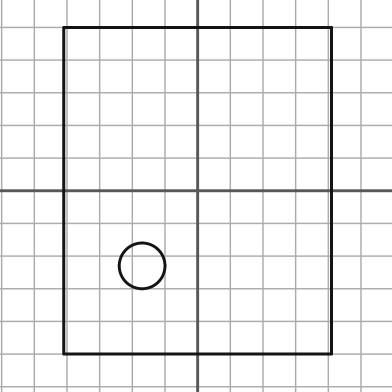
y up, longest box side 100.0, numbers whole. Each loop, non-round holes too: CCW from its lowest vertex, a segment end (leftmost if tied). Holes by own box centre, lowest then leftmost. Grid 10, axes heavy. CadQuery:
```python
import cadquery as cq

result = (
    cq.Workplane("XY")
    .moveTo(-41.0, -50.0)
    .lineTo(41.0, -50.0)
    .lineTo(41.0, 50.0)
    .lineTo(-41.0, 50.0)
    .close()
    .moveTo(-17.0, -23.0)
    .circle(7.0)
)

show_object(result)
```